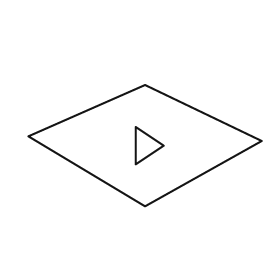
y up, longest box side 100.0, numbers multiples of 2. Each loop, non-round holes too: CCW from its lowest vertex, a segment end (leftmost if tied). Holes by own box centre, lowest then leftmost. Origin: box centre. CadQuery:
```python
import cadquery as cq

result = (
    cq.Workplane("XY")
    .moveTo(0.0, -26.0)
    .lineTo(50.0, 2.0)
    .lineTo(0.0, 26.0)
    .lineTo(-50.0, 4.0)
    .close()
    .moveTo(-4.0, -8.0)
    .lineTo(8.0, 0.0)
    .lineTo(-4.0, 8.0)
    .close()
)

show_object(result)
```